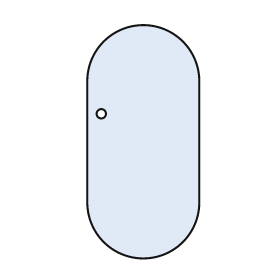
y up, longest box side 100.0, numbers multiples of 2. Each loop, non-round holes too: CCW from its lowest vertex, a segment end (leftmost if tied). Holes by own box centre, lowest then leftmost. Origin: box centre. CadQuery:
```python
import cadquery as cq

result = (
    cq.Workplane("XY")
    .moveTo(-24.0, -26.0)
    .threePointArc((0.0, -50.0), (24.0, -26.0))
    .lineTo(24.0, 26.0)
    .threePointArc((0.0, 50.0), (-24.0, 26.0))
    .close()
    .moveTo(-18.0, 12.0)
    .circle(2.0)
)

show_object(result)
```